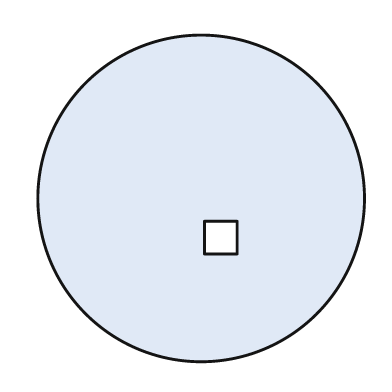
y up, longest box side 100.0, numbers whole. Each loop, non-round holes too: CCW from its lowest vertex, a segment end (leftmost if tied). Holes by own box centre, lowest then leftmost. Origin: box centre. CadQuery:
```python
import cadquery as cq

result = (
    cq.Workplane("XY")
    .moveTo(0.0, 0.0)
    .circle(50.0)
    .moveTo(1.0, -17.0)
    .lineTo(11.0, -17.0)
    .lineTo(11.0, -7.0)
    .lineTo(1.0, -7.0)
    .close()
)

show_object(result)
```